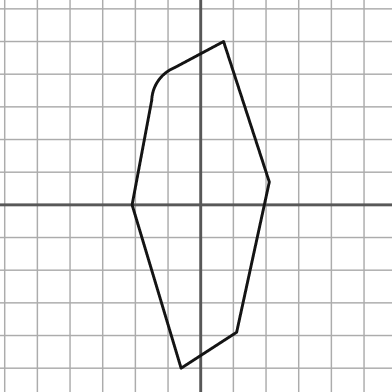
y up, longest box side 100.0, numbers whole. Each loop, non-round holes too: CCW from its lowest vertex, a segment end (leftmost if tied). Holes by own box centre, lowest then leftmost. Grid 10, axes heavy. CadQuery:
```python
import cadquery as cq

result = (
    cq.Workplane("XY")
    .moveTo(-6.0, -50.0)
    .lineTo(11.0, -39.0)
    .lineTo(21.0, 7.0)
    .lineTo(7.0, 50.0)
    .lineTo(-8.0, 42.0)
    .threePointArc((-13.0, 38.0), (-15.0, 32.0))
    .lineTo(-21.0, 0.0)
    .close()
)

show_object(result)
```